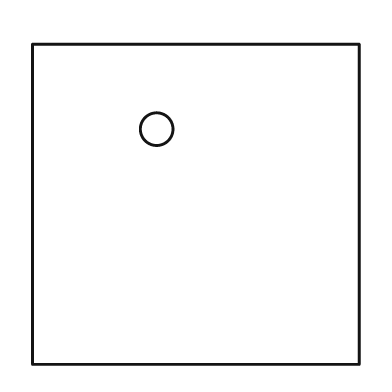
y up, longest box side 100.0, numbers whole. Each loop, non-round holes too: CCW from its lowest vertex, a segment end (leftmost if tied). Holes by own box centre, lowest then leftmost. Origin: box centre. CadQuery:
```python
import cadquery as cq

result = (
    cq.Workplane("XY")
    .moveTo(-50.0, -49.0)
    .lineTo(50.0, -49.0)
    .lineTo(50.0, 49.0)
    .lineTo(-50.0, 49.0)
    .close()
    .moveTo(-12.0, 23.0)
    .circle(5.0)
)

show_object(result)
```